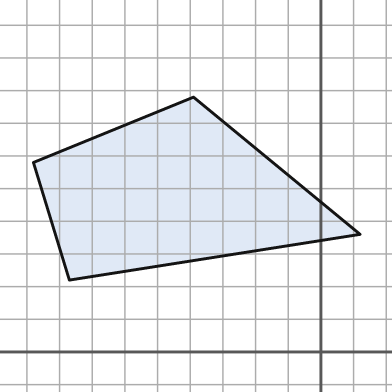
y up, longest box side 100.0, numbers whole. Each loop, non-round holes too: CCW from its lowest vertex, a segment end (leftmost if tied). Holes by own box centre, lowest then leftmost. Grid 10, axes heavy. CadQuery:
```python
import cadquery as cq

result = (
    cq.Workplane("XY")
    .moveTo(-77.0, 22.0)
    .lineTo(12.0, 36.0)
    .lineTo(-39.0, 78.0)
    .lineTo(-88.0, 58.0)
    .close()
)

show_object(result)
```